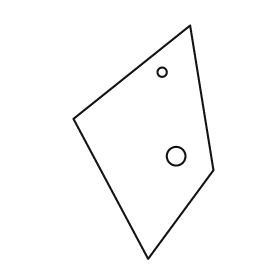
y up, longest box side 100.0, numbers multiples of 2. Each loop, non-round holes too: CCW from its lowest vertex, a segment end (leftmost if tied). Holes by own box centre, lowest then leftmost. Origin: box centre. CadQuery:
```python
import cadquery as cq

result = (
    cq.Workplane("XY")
    .moveTo(2.0, -50.0)
    .lineTo(30.0, -12.0)
    .lineTo(20.0, 50.0)
    .lineTo(-30.0, 10.0)
    .close()
    .moveTo(14.0, -6.0)
    .circle(4.0)
    .moveTo(8.0, 30.0)
    .circle(2.0)
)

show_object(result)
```